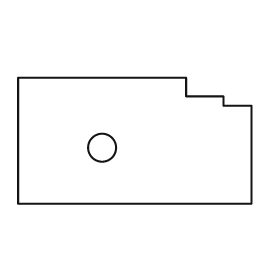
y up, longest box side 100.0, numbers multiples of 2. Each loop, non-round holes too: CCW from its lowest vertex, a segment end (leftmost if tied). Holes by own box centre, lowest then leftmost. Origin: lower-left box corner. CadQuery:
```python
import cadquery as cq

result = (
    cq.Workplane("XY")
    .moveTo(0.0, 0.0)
    .lineTo(100.0, 0.0)
    .lineTo(100.0, 42.0)
    .lineTo(88.0, 42.0)
    .lineTo(88.0, 46.0)
    .lineTo(72.0, 46.0)
    .lineTo(72.0, 54.0)
    .lineTo(0.0, 54.0)
    .close()
    .moveTo(36.0, 24.0)
    .circle(6.0)
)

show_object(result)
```